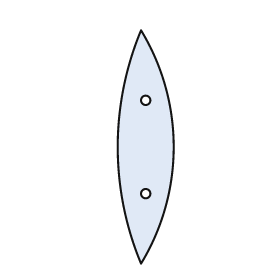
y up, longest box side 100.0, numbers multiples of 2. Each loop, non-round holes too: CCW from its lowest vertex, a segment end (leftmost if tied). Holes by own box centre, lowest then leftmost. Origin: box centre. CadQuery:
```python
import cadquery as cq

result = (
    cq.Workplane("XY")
    .moveTo(-2.0, -50.0)
    .threePointArc((12.0, 0.0), (-2.0, 50.0))
    .threePointArc((-12.0, 0.0), (-2.0, -50.0))
    .close()
    .moveTo(0.0, -20.0)
    .circle(2.0)
    .moveTo(0.0, 20.0)
    .circle(2.0)
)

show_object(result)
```